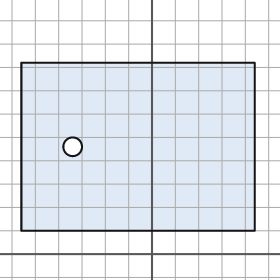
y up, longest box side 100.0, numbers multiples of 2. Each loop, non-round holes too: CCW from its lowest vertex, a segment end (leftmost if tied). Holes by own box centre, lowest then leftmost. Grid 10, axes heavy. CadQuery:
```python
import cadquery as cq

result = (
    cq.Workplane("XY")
    .moveTo(-56.0, 10.0)
    .lineTo(44.0, 10.0)
    .lineTo(44.0, 82.0)
    .lineTo(-56.0, 82.0)
    .close()
    .moveTo(-34.0, 46.0)
    .circle(4.0)
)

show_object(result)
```